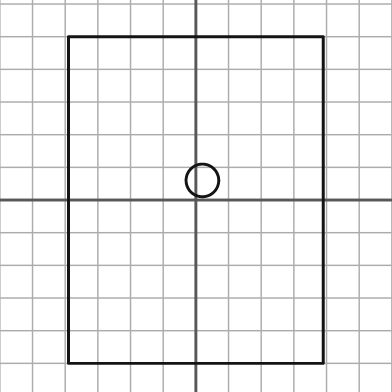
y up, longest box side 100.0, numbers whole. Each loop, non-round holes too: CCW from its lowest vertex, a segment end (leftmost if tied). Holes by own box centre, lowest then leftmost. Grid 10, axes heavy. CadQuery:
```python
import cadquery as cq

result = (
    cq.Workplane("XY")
    .moveTo(-39.0, -50.0)
    .lineTo(39.0, -50.0)
    .lineTo(39.0, 50.0)
    .lineTo(-39.0, 50.0)
    .close()
    .moveTo(2.0, 6.0)
    .circle(5.0)
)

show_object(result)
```